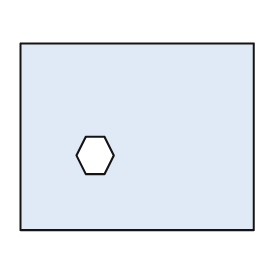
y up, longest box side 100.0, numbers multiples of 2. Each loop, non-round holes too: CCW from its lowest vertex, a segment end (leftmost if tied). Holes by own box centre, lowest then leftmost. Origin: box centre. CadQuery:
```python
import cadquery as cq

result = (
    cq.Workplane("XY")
    .moveTo(-50.0, -40.0)
    .lineTo(50.0, -40.0)
    .lineTo(50.0, 40.0)
    .lineTo(-50.0, 40.0)
    .close()
    .moveTo(-22.0, -16.0)
    .lineTo(-14.0, -16.0)
    .lineTo(-10.0, -8.0)
    .lineTo(-14.0, 0.0)
    .lineTo(-22.0, 0.0)
    .lineTo(-26.0, -8.0)
    .close()
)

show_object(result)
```